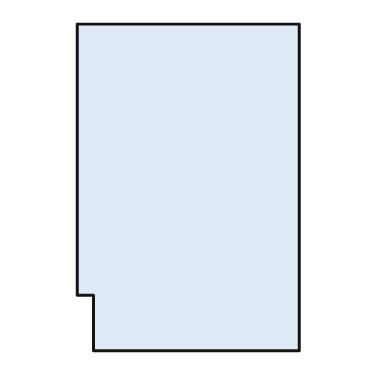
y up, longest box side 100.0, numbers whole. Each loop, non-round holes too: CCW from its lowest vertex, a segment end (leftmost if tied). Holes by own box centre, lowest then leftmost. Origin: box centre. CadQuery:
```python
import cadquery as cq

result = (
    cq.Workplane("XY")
    .moveTo(-29.0, -50.0)
    .lineTo(34.0, -50.0)
    .lineTo(34.0, 50.0)
    .lineTo(-34.0, 50.0)
    .lineTo(-34.0, -33.0)
    .lineTo(-29.0, -33.0)
    .close()
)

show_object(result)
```